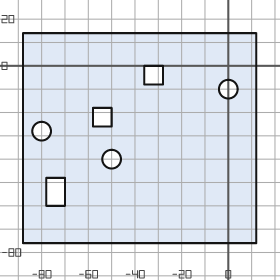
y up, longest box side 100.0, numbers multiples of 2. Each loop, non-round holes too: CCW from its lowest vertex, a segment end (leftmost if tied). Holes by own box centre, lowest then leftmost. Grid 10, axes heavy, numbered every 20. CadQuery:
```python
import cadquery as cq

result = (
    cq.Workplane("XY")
    .moveTo(-88.0, -76.0)
    .lineTo(12.0, -76.0)
    .lineTo(12.0, 14.0)
    .lineTo(-88.0, 14.0)
    .close()
    .moveTo(-78.0, -60.0)
    .lineTo(-70.0, -60.0)
    .lineTo(-70.0, -48.0)
    .lineTo(-78.0, -48.0)
    .close()
    .moveTo(-50.0, -40.0)
    .circle(4.0)
    .moveTo(-80.0, -28.0)
    .circle(4.0)
    .moveTo(-58.0, -26.0)
    .lineTo(-50.0, -26.0)
    .lineTo(-50.0, -18.0)
    .lineTo(-58.0, -18.0)
    .close()
    .moveTo(0.0, -10.0)
    .circle(4.0)
    .moveTo(-36.0, -8.0)
    .lineTo(-28.0, -8.0)
    .lineTo(-28.0, 0.0)
    .lineTo(-36.0, 0.0)
    .close()
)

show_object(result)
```